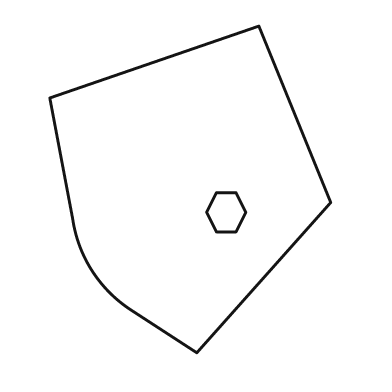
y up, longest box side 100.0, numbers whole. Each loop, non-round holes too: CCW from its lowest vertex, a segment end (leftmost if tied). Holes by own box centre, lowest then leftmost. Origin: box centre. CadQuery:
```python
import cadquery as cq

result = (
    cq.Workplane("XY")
    .moveTo(2.0, -50.0)
    .lineTo(43.0, -4.0)
    .lineTo(21.0, 50.0)
    .lineTo(-43.0, 28.0)
    .lineTo(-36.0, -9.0)
    .threePointArc((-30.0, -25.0), (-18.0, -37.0))
    .close()
    .moveTo(8.0, -13.0)
    .lineTo(14.0, -13.0)
    .lineTo(17.0, -7.0)
    .lineTo(14.0, -1.0)
    .lineTo(8.0, -1.0)
    .lineTo(5.0, -7.0)
    .close()
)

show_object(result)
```